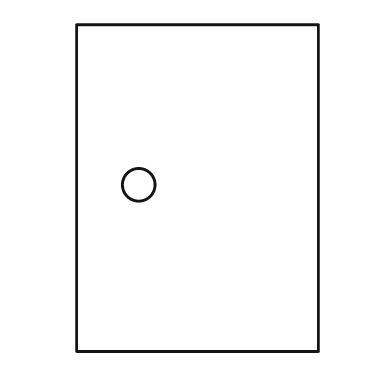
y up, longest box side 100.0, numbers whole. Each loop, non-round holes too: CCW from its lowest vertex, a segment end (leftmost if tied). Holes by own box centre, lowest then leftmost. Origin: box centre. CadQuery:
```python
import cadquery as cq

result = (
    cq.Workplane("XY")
    .moveTo(-37.0, -50.0)
    .lineTo(37.0, -50.0)
    .lineTo(37.0, 50.0)
    .lineTo(-37.0, 50.0)
    .close()
    .moveTo(-18.0, 1.0)
    .circle(5.0)
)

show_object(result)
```